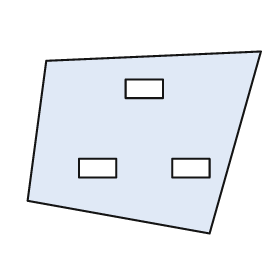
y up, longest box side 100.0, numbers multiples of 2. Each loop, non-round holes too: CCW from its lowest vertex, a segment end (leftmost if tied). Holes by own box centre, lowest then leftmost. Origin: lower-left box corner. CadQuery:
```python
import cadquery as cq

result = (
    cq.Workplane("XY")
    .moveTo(78.0, 0.0)
    .lineTo(100.0, 78.0)
    .lineTo(8.0, 74.0)
    .lineTo(0.0, 14.0)
    .close()
    .moveTo(22.0, 24.0)
    .lineTo(38.0, 24.0)
    .lineTo(38.0, 32.0)
    .lineTo(22.0, 32.0)
    .close()
    .moveTo(62.0, 24.0)
    .lineTo(78.0, 24.0)
    .lineTo(78.0, 32.0)
    .lineTo(62.0, 32.0)
    .close()
    .moveTo(42.0, 58.0)
    .lineTo(58.0, 58.0)
    .lineTo(58.0, 66.0)
    .lineTo(42.0, 66.0)
    .close()
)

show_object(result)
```